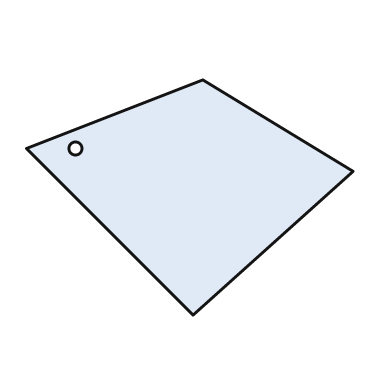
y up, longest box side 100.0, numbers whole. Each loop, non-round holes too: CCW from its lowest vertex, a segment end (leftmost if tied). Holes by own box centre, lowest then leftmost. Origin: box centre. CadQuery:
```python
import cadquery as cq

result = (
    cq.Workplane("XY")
    .moveTo(1.0, -36.0)
    .lineTo(50.0, 8.0)
    .lineTo(4.0, 36.0)
    .lineTo(-50.0, 15.0)
    .close()
    .moveTo(-35.0, 15.0)
    .circle(2.0)
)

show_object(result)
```